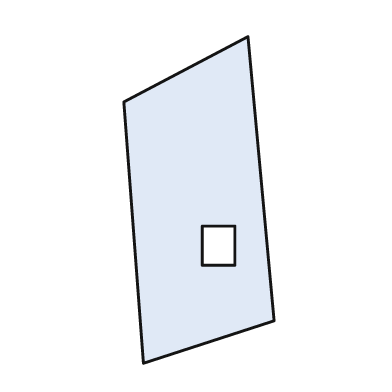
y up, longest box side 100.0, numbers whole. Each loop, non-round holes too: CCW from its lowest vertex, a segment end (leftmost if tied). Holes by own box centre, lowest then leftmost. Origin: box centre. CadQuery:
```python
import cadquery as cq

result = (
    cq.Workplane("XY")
    .moveTo(-17.0, -50.0)
    .lineTo(23.0, -37.0)
    .lineTo(15.0, 50.0)
    .lineTo(-23.0, 30.0)
    .close()
    .moveTo(1.0, -20.0)
    .lineTo(11.0, -20.0)
    .lineTo(11.0, -8.0)
    .lineTo(1.0, -8.0)
    .close()
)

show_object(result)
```